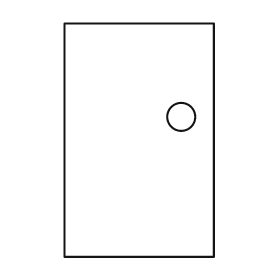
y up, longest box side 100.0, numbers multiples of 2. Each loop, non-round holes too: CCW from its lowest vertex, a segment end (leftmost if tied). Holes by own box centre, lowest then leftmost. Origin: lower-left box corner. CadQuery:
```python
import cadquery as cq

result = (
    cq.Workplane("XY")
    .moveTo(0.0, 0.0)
    .lineTo(64.0, 0.0)
    .lineTo(64.0, 100.0)
    .lineTo(0.0, 100.0)
    .close()
    .moveTo(50.0, 60.0)
    .circle(6.0)
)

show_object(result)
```